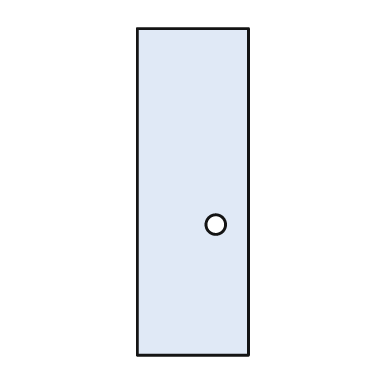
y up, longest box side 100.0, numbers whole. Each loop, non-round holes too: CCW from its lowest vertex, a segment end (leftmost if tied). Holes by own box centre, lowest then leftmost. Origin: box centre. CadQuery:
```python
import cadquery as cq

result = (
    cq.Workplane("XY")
    .moveTo(-17.0, -50.0)
    .lineTo(17.0, -50.0)
    .lineTo(17.0, 50.0)
    .lineTo(-17.0, 50.0)
    .close()
    .moveTo(7.0, -10.0)
    .circle(3.0)
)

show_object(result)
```